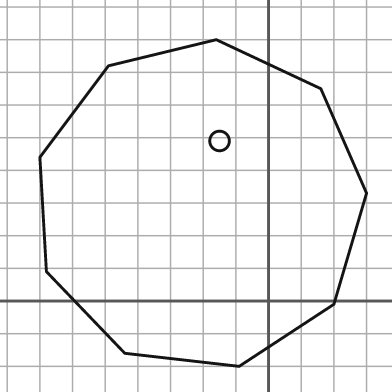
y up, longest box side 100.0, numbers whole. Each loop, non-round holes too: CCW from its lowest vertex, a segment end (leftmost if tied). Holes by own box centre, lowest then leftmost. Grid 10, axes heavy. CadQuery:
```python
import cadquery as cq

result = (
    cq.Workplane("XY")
    .moveTo(-9.0, -20.0)
    .lineTo(20.0, -1.0)
    .lineTo(30.0, 33.0)
    .lineTo(16.0, 65.0)
    .lineTo(-16.0, 80.0)
    .lineTo(-49.0, 72.0)
    .lineTo(-70.0, 44.0)
    .lineTo(-68.0, 9.0)
    .lineTo(-44.0, -16.0)
    .close()
    .moveTo(-15.0, 49.0)
    .circle(3.0)
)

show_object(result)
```